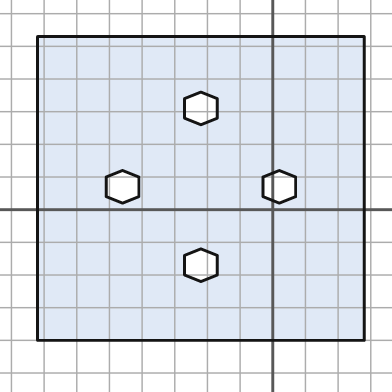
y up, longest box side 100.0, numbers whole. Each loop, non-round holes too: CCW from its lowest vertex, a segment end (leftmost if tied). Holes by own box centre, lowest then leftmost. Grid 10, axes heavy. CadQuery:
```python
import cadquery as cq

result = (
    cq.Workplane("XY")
    .moveTo(-72.0, -40.0)
    .lineTo(28.0, -40.0)
    .lineTo(28.0, 53.0)
    .lineTo(-72.0, 53.0)
    .close()
    .moveTo(-22.0, -22.0)
    .lineTo(-17.0, -20.0)
    .lineTo(-17.0, -14.0)
    .lineTo(-22.0, -12.0)
    .lineTo(-27.0, -14.0)
    .lineTo(-27.0, -20.0)
    .close()
    .moveTo(-46.0, 2.0)
    .lineTo(-41.0, 4.0)
    .lineTo(-41.0, 10.0)
    .lineTo(-46.0, 12.0)
    .lineTo(-51.0, 10.0)
    .lineTo(-51.0, 4.0)
    .close()
    .moveTo(2.0, 2.0)
    .lineTo(7.0, 4.0)
    .lineTo(7.0, 10.0)
    .lineTo(2.0, 12.0)
    .lineTo(-3.0, 10.0)
    .lineTo(-3.0, 4.0)
    .close()
    .moveTo(-22.0, 26.0)
    .lineTo(-17.0, 28.0)
    .lineTo(-17.0, 34.0)
    .lineTo(-22.0, 36.0)
    .lineTo(-27.0, 34.0)
    .lineTo(-27.0, 28.0)
    .close()
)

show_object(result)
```